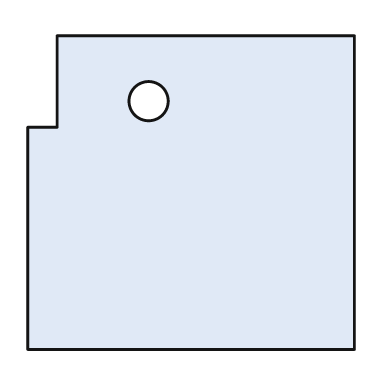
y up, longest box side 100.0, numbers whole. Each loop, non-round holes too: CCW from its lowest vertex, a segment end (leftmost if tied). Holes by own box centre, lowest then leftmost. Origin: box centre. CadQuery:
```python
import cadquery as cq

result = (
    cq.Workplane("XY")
    .moveTo(-50.0, -48.0)
    .lineTo(50.0, -48.0)
    .lineTo(50.0, 48.0)
    .lineTo(-41.0, 48.0)
    .lineTo(-41.0, 20.0)
    .lineTo(-50.0, 20.0)
    .close()
    .moveTo(-13.0, 28.0)
    .circle(6.0)
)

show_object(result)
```